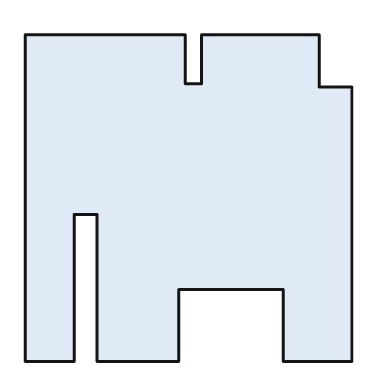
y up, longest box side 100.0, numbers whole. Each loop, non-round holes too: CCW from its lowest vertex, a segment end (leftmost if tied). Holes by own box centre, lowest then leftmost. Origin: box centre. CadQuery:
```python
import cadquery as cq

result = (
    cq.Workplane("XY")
    .moveTo(-50.0, -50.0)
    .lineTo(-35.0, -50.0)
    .lineTo(-35.0, -5.0)
    .lineTo(-28.0, -5.0)
    .lineTo(-28.0, -50.0)
    .lineTo(-3.0, -50.0)
    .lineTo(-3.0, -28.0)
    .lineTo(29.0, -28.0)
    .lineTo(29.0, -50.0)
    .lineTo(50.0, -50.0)
    .lineTo(50.0, 34.0)
    .lineTo(40.0, 34.0)
    .lineTo(40.0, 50.0)
    .lineTo(4.0, 50.0)
    .lineTo(4.0, 35.0)
    .lineTo(-1.0, 35.0)
    .lineTo(-1.0, 50.0)
    .lineTo(-50.0, 50.0)
    .close()
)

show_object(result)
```